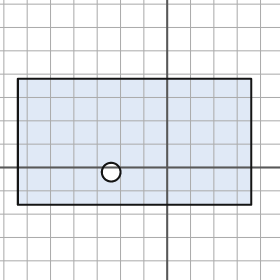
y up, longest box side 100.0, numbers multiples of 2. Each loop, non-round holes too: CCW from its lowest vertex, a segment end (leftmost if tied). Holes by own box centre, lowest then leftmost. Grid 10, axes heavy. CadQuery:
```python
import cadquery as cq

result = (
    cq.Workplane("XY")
    .moveTo(-64.0, -16.0)
    .lineTo(36.0, -16.0)
    .lineTo(36.0, 38.0)
    .lineTo(-64.0, 38.0)
    .close()
    .moveTo(-24.0, -2.0)
    .circle(4.0)
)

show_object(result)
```